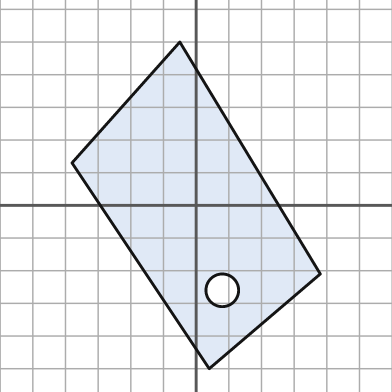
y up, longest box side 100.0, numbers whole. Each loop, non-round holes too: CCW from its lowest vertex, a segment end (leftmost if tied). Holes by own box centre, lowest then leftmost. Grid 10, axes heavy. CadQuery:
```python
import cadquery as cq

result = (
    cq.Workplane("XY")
    .moveTo(4.0, -50.0)
    .lineTo(38.0, -21.0)
    .lineTo(-5.0, 50.0)
    .lineTo(-38.0, 13.0)
    .close()
    .moveTo(8.0, -26.0)
    .circle(5.0)
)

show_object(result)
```